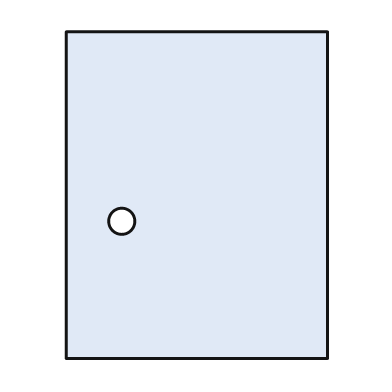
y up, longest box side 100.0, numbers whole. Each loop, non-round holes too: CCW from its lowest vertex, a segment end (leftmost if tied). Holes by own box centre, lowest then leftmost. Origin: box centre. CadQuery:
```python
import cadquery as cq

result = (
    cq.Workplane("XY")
    .moveTo(-40.0, -50.0)
    .lineTo(40.0, -50.0)
    .lineTo(40.0, 50.0)
    .lineTo(-40.0, 50.0)
    .close()
    .moveTo(-23.0, -8.0)
    .circle(4.0)
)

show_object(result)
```